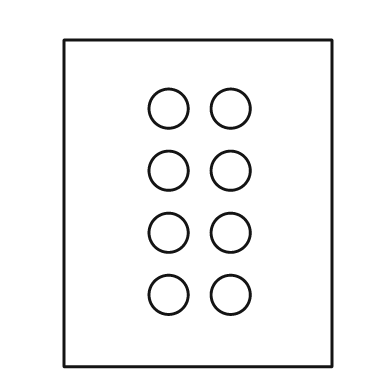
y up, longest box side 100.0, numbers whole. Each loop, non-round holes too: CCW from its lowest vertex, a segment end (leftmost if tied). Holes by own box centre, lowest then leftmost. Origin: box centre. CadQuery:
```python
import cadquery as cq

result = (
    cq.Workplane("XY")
    .moveTo(-41.0, -50.0)
    .lineTo(41.0, -50.0)
    .lineTo(41.0, 50.0)
    .lineTo(-41.0, 50.0)
    .close()
    .moveTo(-9.0, -28.0)
    .circle(6.0)
    .moveTo(10.0, -28.0)
    .circle(6.0)
    .moveTo(-9.0, -9.0)
    .circle(6.0)
    .moveTo(10.0, -9.0)
    .circle(6.0)
    .moveTo(-9.0, 10.0)
    .circle(6.0)
    .moveTo(10.0, 10.0)
    .circle(6.0)
    .moveTo(-9.0, 29.0)
    .circle(6.0)
    .moveTo(10.0, 29.0)
    .circle(6.0)
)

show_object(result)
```